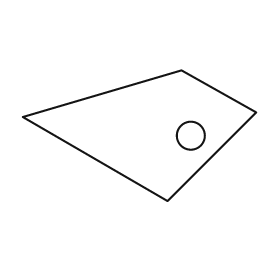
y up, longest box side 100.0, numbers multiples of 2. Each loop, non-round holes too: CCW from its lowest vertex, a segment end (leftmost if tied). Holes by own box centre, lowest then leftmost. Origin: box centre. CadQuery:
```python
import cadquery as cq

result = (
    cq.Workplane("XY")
    .moveTo(12.0, -28.0)
    .lineTo(50.0, 10.0)
    .lineTo(18.0, 28.0)
    .lineTo(-50.0, 8.0)
    .close()
    .moveTo(22.0, 0.0)
    .circle(6.0)
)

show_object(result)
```